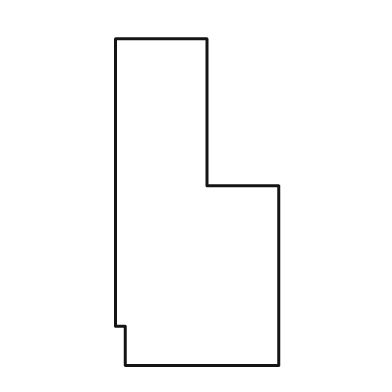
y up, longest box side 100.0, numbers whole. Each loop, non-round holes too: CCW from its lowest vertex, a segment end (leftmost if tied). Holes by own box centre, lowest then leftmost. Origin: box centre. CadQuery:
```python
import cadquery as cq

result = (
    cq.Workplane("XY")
    .moveTo(-22.0, -50.0)
    .lineTo(25.0, -50.0)
    .lineTo(25.0, 5.0)
    .lineTo(3.0, 5.0)
    .lineTo(3.0, 50.0)
    .lineTo(-25.0, 50.0)
    .lineTo(-25.0, -38.0)
    .lineTo(-22.0, -38.0)
    .close()
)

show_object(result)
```